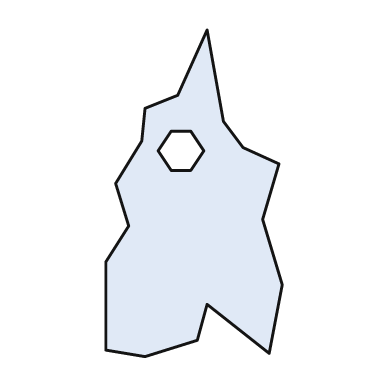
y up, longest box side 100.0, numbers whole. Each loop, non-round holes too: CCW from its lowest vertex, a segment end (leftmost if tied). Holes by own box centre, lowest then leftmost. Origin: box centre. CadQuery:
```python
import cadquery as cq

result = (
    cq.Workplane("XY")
    .moveTo(-15.0, -50.0)
    .lineTo(1.0, -45.0)
    .lineTo(4.0, -34.0)
    .lineTo(23.0, -49.0)
    .lineTo(27.0, -28.0)
    .lineTo(21.0, -8.0)
    .lineTo(26.0, 9.0)
    .lineTo(15.0, 14.0)
    .lineTo(9.0, 22.0)
    .lineTo(4.0, 50.0)
    .lineTo(-5.0, 30.0)
    .lineTo(-15.0, 26.0)
    .lineTo(-16.0, 16.0)
    .lineTo(-24.0, 3.0)
    .lineTo(-20.0, -10.0)
    .lineTo(-27.0, -21.0)
    .lineTo(-27.0, -48.0)
    .close()
    .moveTo(-7.0, 7.0)
    .lineTo(-1.0, 7.0)
    .lineTo(3.0, 13.0)
    .lineTo(-1.0, 19.0)
    .lineTo(-7.0, 19.0)
    .lineTo(-11.0, 13.0)
    .close()
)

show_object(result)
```